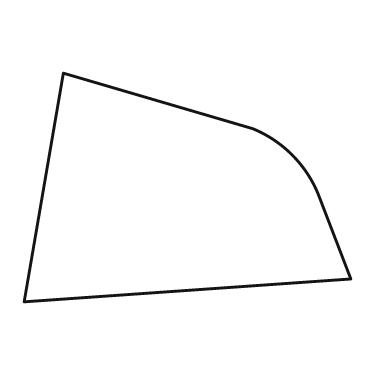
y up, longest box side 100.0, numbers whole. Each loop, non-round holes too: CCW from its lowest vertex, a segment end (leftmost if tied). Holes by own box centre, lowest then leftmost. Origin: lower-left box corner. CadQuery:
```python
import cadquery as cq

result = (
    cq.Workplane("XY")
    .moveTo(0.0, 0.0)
    .lineTo(100.0, 7.0)
    .lineTo(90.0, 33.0)
    .threePointArc((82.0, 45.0), (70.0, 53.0))
    .lineTo(12.0, 70.0)
    .close()
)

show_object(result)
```